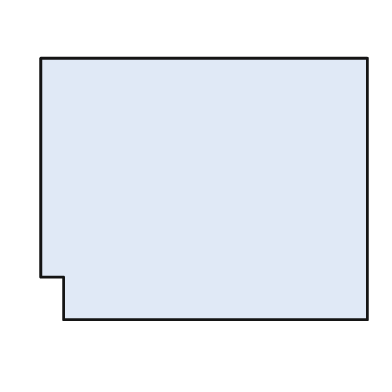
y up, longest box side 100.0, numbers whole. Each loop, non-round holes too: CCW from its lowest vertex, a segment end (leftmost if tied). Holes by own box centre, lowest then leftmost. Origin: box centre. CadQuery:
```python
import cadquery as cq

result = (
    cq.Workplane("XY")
    .moveTo(-43.0, -40.0)
    .lineTo(50.0, -40.0)
    .lineTo(50.0, 40.0)
    .lineTo(-50.0, 40.0)
    .lineTo(-50.0, -27.0)
    .lineTo(-43.0, -27.0)
    .close()
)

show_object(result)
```